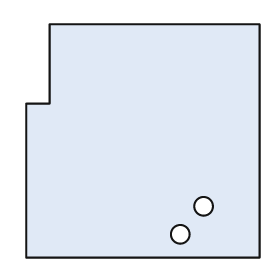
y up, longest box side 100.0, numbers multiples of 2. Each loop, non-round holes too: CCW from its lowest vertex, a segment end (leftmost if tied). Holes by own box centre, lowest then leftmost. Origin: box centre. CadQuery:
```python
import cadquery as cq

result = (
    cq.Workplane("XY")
    .moveTo(-50.0, -50.0)
    .lineTo(50.0, -50.0)
    .lineTo(50.0, 50.0)
    .lineTo(-40.0, 50.0)
    .lineTo(-40.0, 16.0)
    .lineTo(-50.0, 16.0)
    .close()
    .moveTo(16.0, -40.0)
    .circle(4.0)
    .moveTo(26.0, -28.0)
    .circle(4.0)
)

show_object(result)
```